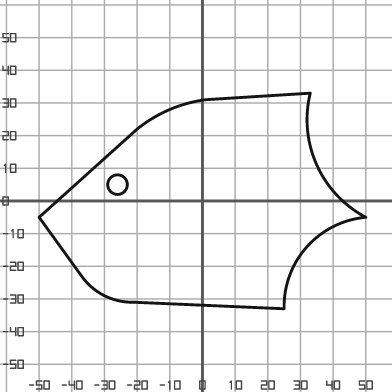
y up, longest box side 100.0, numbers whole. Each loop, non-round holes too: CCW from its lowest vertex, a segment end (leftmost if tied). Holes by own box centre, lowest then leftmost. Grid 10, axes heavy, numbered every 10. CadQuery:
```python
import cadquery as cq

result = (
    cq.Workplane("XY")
    .moveTo(25.0, -33.0)
    .threePointArc((32.0, -14.0), (50.0, -5.0))
    .threePointArc((35.0, 11.0), (33.0, 33.0))
    .lineTo(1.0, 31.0)
    .threePointArc((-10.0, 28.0), (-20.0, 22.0))
    .lineTo(-50.0, -5.0)
    .lineTo(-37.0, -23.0)
    .threePointArc((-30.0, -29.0), (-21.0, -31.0))
    .close()
    .moveTo(-26.0, 5.0)
    .circle(3.0)
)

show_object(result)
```